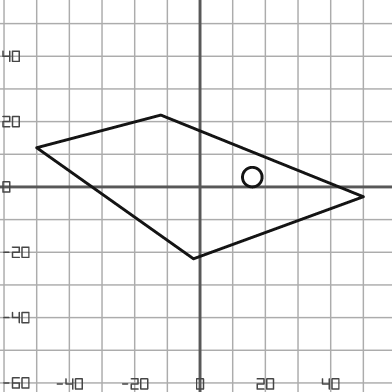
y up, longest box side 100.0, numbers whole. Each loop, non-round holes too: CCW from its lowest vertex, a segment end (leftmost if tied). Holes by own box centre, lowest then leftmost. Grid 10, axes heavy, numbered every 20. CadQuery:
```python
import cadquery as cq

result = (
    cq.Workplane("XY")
    .moveTo(-2.0, -22.0)
    .lineTo(50.0, -3.0)
    .lineTo(-12.0, 22.0)
    .lineTo(-50.0, 12.0)
    .close()
    .moveTo(16.0, 3.0)
    .circle(3.0)
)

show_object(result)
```